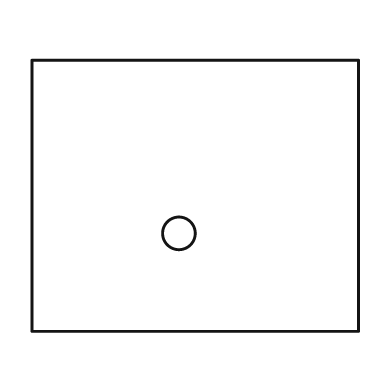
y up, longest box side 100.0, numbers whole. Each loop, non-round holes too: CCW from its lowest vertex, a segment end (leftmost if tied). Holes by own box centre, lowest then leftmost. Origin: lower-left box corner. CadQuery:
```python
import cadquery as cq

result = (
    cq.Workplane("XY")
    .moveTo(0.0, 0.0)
    .lineTo(100.0, 0.0)
    .lineTo(100.0, 83.0)
    .lineTo(0.0, 83.0)
    .close()
    .moveTo(45.0, 30.0)
    .circle(5.0)
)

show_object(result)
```